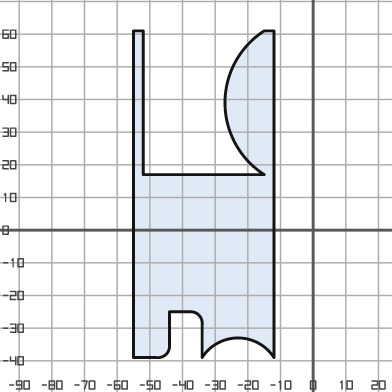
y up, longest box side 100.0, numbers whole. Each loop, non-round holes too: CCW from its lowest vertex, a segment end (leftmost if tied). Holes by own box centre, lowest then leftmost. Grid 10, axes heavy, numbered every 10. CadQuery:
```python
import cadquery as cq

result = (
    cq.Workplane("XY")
    .moveTo(-55.0, -39.0)
    .lineTo(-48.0, -39.0)
    .threePointArc((-45.0, -38.0), (-44.0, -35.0))
    .lineTo(-44.0, -25.0)
    .lineTo(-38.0, -25.0)
    .threePointArc((-35.0, -26.0), (-34.0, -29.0))
    .lineTo(-34.0, -39.0)
    .threePointArc((-23.0, -33.0), (-12.0, -39.0))
    .lineTo(-12.0, 61.0)
    .lineTo(-15.0, 61.0)
    .threePointArc((-27.0, 39.0), (-15.0, 17.0))
    .lineTo(-52.0, 17.0)
    .lineTo(-52.0, 61.0)
    .lineTo(-55.0, 61.0)
    .close()
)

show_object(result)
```